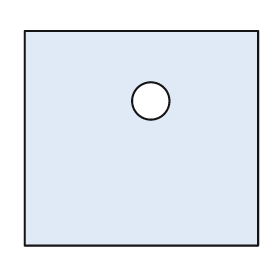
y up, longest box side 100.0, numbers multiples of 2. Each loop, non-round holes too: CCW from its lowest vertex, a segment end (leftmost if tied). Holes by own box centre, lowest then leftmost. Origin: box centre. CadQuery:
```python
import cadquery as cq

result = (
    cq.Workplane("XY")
    .moveTo(-50.0, -46.0)
    .lineTo(50.0, -46.0)
    .lineTo(50.0, 46.0)
    .lineTo(-50.0, 46.0)
    .close()
    .moveTo(4.0, 16.0)
    .circle(8.0)
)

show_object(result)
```